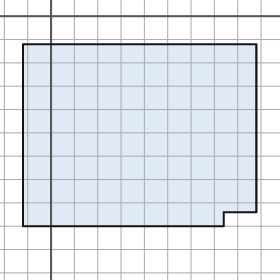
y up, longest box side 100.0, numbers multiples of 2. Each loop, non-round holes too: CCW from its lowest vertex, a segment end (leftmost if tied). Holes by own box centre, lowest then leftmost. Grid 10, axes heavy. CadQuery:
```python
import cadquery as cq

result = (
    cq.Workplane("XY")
    .moveTo(-12.0, -90.0)
    .lineTo(74.0, -90.0)
    .lineTo(74.0, -84.0)
    .lineTo(88.0, -84.0)
    .lineTo(88.0, -12.0)
    .lineTo(-12.0, -12.0)
    .close()
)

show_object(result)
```